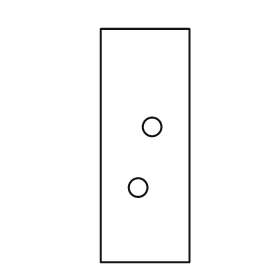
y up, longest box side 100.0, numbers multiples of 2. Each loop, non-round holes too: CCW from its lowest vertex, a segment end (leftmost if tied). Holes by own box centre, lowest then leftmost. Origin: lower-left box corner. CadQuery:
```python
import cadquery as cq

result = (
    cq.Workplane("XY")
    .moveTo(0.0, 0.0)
    .lineTo(38.0, 0.0)
    .lineTo(38.0, 100.0)
    .lineTo(0.0, 100.0)
    .close()
    .moveTo(16.0, 32.0)
    .circle(4.0)
    .moveTo(22.0, 58.0)
    .circle(4.0)
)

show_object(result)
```